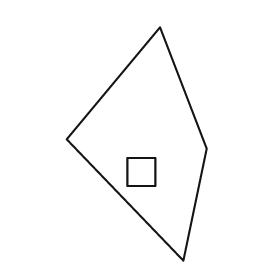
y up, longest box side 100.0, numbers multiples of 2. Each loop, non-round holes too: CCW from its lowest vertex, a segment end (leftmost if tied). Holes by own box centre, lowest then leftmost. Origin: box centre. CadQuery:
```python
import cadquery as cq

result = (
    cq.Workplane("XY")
    .moveTo(20.0, -50.0)
    .lineTo(30.0, -2.0)
    .lineTo(10.0, 50.0)
    .lineTo(-30.0, 2.0)
    .close()
    .moveTo(-4.0, -18.0)
    .lineTo(8.0, -18.0)
    .lineTo(8.0, -6.0)
    .lineTo(-4.0, -6.0)
    .close()
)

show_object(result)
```